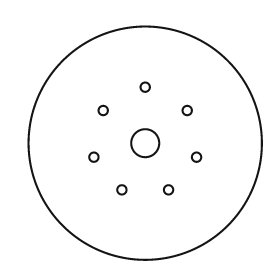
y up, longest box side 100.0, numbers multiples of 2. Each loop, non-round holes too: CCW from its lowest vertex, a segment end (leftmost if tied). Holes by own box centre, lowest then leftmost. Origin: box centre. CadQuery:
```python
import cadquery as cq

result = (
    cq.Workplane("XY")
    .moveTo(0.0, 0.0)
    .circle(50.0)
    .moveTo(-10.0, -20.0)
    .circle(2.0)
    .moveTo(10.0, -20.0)
    .circle(2.0)
    .moveTo(-22.0, -6.0)
    .circle(2.0)
    .moveTo(22.0, -6.0)
    .circle(2.0)
    .moveTo(0.0, 0.0)
    .circle(6.0)
    .moveTo(-18.0, 14.0)
    .circle(2.0)
    .moveTo(18.0, 14.0)
    .circle(2.0)
    .moveTo(0.0, 24.0)
    .circle(2.0)
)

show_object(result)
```